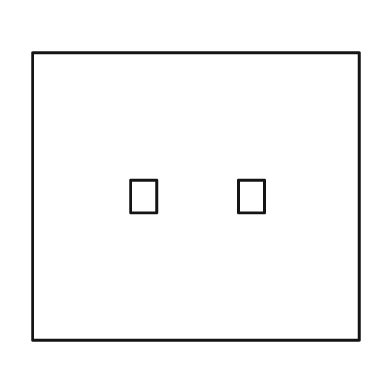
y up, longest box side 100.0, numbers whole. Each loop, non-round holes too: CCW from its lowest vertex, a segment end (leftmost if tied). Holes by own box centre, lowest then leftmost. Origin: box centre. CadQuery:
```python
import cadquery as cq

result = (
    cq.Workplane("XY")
    .moveTo(-50.0, -44.0)
    .lineTo(50.0, -44.0)
    .lineTo(50.0, 44.0)
    .lineTo(-50.0, 44.0)
    .close()
    .moveTo(-20.0, -5.0)
    .lineTo(-12.0, -5.0)
    .lineTo(-12.0, 5.0)
    .lineTo(-20.0, 5.0)
    .close()
    .moveTo(13.0, -5.0)
    .lineTo(21.0, -5.0)
    .lineTo(21.0, 5.0)
    .lineTo(13.0, 5.0)
    .close()
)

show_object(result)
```